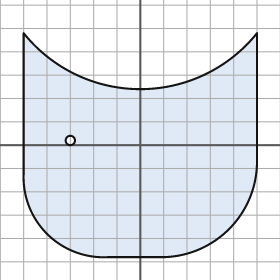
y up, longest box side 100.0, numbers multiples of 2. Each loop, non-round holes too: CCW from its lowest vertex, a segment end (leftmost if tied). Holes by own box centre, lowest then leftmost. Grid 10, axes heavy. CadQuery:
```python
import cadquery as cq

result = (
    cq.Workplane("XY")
    .moveTo(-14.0, -48.0)
    .lineTo(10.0, -48.0)
    .threePointArc((38.0, -36.0), (50.0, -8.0))
    .lineTo(50.0, 48.0)
    .threePointArc((0.0, 24.0), (-50.0, 48.0))
    .lineTo(-50.0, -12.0)
    .threePointArc((-40.0, -38.0), (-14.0, -48.0))
    .close()
    .moveTo(-30.0, 2.0)
    .circle(2.0)
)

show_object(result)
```